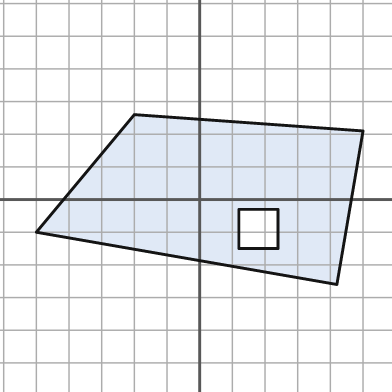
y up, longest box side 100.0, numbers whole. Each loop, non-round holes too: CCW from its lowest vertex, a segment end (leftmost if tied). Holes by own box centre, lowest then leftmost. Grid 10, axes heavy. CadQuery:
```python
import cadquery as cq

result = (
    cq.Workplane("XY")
    .moveTo(42.0, -26.0)
    .lineTo(50.0, 21.0)
    .lineTo(-20.0, 26.0)
    .lineTo(-50.0, -10.0)
    .close()
    .moveTo(12.0, -15.0)
    .lineTo(24.0, -15.0)
    .lineTo(24.0, -3.0)
    .lineTo(12.0, -3.0)
    .close()
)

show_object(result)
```